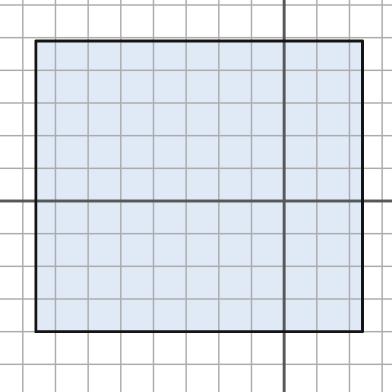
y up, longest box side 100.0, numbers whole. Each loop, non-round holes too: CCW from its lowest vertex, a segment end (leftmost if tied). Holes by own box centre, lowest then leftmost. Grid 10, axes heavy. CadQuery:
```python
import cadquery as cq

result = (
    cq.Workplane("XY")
    .moveTo(-76.0, -40.0)
    .lineTo(24.0, -40.0)
    .lineTo(24.0, 49.0)
    .lineTo(-76.0, 49.0)
    .close()
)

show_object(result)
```